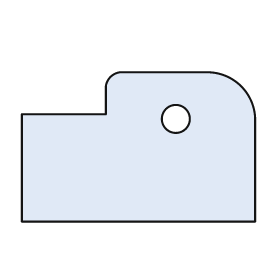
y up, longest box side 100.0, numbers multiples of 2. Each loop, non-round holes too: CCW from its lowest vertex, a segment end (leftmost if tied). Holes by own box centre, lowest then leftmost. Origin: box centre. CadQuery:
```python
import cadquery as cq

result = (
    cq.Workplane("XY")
    .moveTo(-50.0, -32.0)
    .lineTo(50.0, -32.0)
    .lineTo(50.0, 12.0)
    .threePointArc((44.0, 26.0), (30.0, 32.0))
    .lineTo(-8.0, 32.0)
    .threePointArc((-12.0, 30.0), (-14.0, 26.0))
    .lineTo(-14.0, 14.0)
    .lineTo(-50.0, 14.0)
    .close()
    .moveTo(16.0, 12.0)
    .circle(6.0)
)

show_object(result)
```